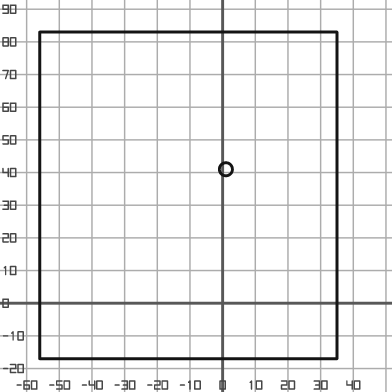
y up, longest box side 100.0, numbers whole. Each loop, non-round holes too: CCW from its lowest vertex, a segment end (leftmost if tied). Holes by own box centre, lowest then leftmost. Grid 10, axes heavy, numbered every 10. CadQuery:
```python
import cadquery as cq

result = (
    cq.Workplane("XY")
    .moveTo(-56.0, -17.0)
    .lineTo(35.0, -17.0)
    .lineTo(35.0, 83.0)
    .lineTo(-56.0, 83.0)
    .close()
    .moveTo(1.0, 41.0)
    .circle(2.0)
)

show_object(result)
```